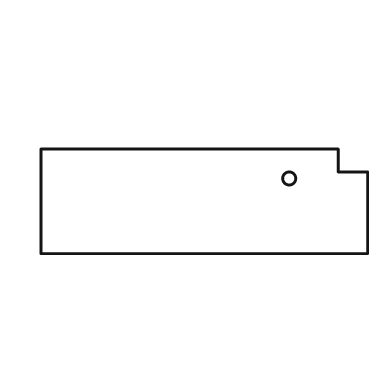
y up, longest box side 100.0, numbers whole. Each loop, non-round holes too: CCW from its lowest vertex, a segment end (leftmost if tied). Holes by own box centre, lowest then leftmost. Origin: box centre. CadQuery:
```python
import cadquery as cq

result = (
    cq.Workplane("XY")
    .moveTo(-50.0, -16.0)
    .lineTo(50.0, -16.0)
    .lineTo(50.0, 9.0)
    .lineTo(41.0, 9.0)
    .lineTo(41.0, 16.0)
    .lineTo(-50.0, 16.0)
    .close()
    .moveTo(26.0, 7.0)
    .circle(2.0)
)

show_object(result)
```